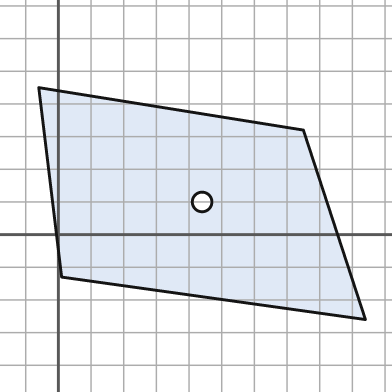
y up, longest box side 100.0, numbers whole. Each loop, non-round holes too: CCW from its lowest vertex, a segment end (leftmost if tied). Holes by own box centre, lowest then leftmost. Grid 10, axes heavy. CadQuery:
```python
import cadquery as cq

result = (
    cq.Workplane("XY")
    .moveTo(94.0, -26.0)
    .lineTo(75.0, 32.0)
    .lineTo(-6.0, 45.0)
    .lineTo(1.0, -13.0)
    .close()
    .moveTo(44.0, 10.0)
    .circle(3.0)
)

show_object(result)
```